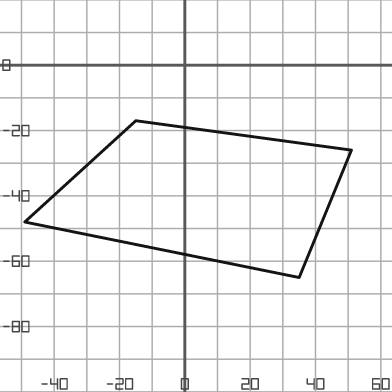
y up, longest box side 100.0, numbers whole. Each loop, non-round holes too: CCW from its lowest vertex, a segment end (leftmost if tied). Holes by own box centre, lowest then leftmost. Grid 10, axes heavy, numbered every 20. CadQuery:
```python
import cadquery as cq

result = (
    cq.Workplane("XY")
    .moveTo(35.0, -65.0)
    .lineTo(51.0, -26.0)
    .lineTo(-15.0, -17.0)
    .lineTo(-49.0, -48.0)
    .close()
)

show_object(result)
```